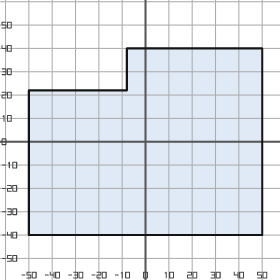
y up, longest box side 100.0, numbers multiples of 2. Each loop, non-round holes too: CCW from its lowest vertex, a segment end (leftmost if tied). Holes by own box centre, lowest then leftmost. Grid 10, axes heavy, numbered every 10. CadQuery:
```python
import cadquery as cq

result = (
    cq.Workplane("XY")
    .moveTo(-50.0, -40.0)
    .lineTo(50.0, -40.0)
    .lineTo(50.0, 40.0)
    .lineTo(-8.0, 40.0)
    .lineTo(-8.0, 22.0)
    .lineTo(-50.0, 22.0)
    .close()
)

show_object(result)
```